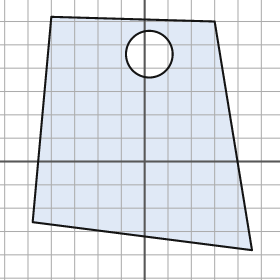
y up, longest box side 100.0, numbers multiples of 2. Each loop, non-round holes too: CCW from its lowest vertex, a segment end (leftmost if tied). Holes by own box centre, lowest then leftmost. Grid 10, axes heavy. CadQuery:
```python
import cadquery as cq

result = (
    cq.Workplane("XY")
    .moveTo(46.0, -38.0)
    .lineTo(30.0, 60.0)
    .lineTo(-40.0, 62.0)
    .lineTo(-48.0, -26.0)
    .close()
    .moveTo(2.0, 46.0)
    .circle(10.0)
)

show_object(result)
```